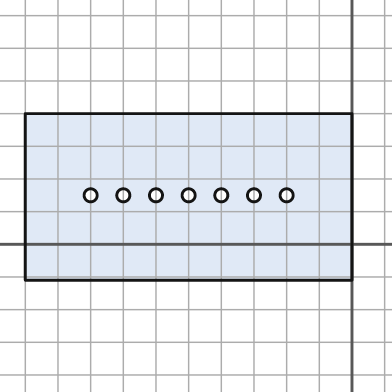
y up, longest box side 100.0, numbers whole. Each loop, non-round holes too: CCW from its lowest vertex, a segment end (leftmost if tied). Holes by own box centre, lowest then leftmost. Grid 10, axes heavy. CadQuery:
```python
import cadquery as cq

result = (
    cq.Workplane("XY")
    .moveTo(-100.0, -11.0)
    .lineTo(0.0, -11.0)
    .lineTo(0.0, 40.0)
    .lineTo(-100.0, 40.0)
    .close()
    .moveTo(-80.0, 15.0)
    .circle(2.0)
    .moveTo(-70.0, 15.0)
    .circle(2.0)
    .moveTo(-60.0, 15.0)
    .circle(2.0)
    .moveTo(-50.0, 15.0)
    .circle(2.0)
    .moveTo(-40.0, 15.0)
    .circle(2.0)
    .moveTo(-30.0, 15.0)
    .circle(2.0)
    .moveTo(-20.0, 15.0)
    .circle(2.0)
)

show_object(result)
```